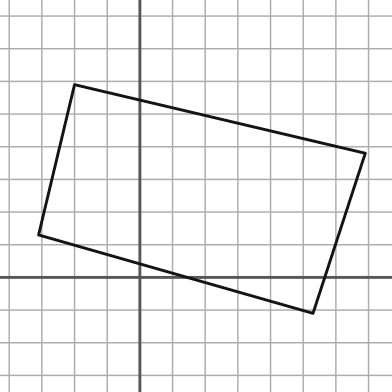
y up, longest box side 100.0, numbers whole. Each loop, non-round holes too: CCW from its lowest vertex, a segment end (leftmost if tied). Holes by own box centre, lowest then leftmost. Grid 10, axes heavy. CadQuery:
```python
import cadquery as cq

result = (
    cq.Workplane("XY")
    .moveTo(53.0, -11.0)
    .lineTo(69.0, 38.0)
    .lineTo(-20.0, 59.0)
    .lineTo(-31.0, 13.0)
    .close()
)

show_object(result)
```